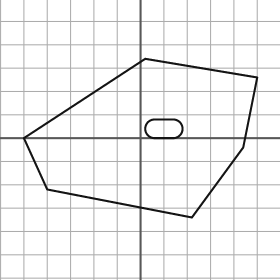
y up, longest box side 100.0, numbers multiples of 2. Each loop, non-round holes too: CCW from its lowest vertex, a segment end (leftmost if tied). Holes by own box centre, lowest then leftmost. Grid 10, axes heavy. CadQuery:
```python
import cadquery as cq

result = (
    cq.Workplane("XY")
    .moveTo(22.0, -34.0)
    .lineTo(44.0, -4.0)
    .lineTo(50.0, 26.0)
    .lineTo(2.0, 34.0)
    .lineTo(-50.0, 0.0)
    .lineTo(-40.0, -22.0)
    .close()
    .moveTo(6.0, 0.0)
    .lineTo(14.0, 0.0)
    .threePointArc((18.0, 4.0), (14.0, 8.0))
    .lineTo(6.0, 8.0)
    .threePointArc((2.0, 4.0), (6.0, 0.0))
    .close()
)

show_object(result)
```